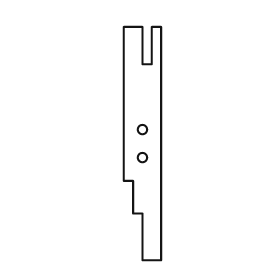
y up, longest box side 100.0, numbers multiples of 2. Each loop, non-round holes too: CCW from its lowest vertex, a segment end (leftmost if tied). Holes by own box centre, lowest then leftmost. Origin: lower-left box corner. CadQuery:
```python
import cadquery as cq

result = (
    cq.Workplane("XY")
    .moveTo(8.0, 0.0)
    .lineTo(16.0, 0.0)
    .lineTo(16.0, 100.0)
    .lineTo(12.0, 100.0)
    .lineTo(12.0, 84.0)
    .lineTo(8.0, 84.0)
    .lineTo(8.0, 100.0)
    .lineTo(0.0, 100.0)
    .lineTo(0.0, 34.0)
    .lineTo(4.0, 34.0)
    .lineTo(4.0, 20.0)
    .lineTo(8.0, 20.0)
    .close()
    .moveTo(8.0, 44.0)
    .circle(2.0)
    .moveTo(8.0, 56.0)
    .circle(2.0)
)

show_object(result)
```